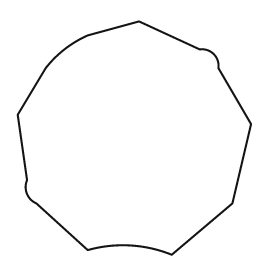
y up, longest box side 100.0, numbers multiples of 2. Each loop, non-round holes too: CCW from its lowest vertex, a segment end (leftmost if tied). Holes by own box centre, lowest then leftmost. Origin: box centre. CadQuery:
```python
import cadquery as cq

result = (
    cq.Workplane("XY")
    .moveTo(16.0, -50.0)
    .lineTo(42.0, -28.0)
    .lineTo(50.0, 6.0)
    .lineTo(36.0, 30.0)
    .threePointArc((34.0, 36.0), (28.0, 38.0))
    .lineTo(2.0, 50.0)
    .lineTo(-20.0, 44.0)
    .threePointArc((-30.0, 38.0), (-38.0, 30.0))
    .lineTo(-50.0, 10.0)
    .lineTo(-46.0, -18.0)
    .threePointArc((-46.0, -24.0), (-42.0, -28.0))
    .lineTo(-20.0, -48.0)
    .threePointArc((-2.0, -46.0), (16.0, -50.0))
    .close()
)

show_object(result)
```